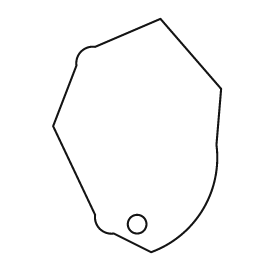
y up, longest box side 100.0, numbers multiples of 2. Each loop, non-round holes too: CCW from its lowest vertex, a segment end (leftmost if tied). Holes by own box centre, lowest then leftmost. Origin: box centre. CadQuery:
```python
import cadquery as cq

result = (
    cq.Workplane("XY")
    .moveTo(6.0, -50.0)
    .threePointArc((28.0, -32.0), (34.0, -4.0))
    .lineTo(36.0, 20.0)
    .lineTo(10.0, 50.0)
    .lineTo(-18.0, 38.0)
    .threePointArc((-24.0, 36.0), (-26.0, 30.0))
    .lineTo(-36.0, 4.0)
    .lineTo(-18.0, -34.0)
    .threePointArc((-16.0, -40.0), (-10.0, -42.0))
    .close()
    .moveTo(0.0, -38.0)
    .circle(4.0)
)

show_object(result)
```